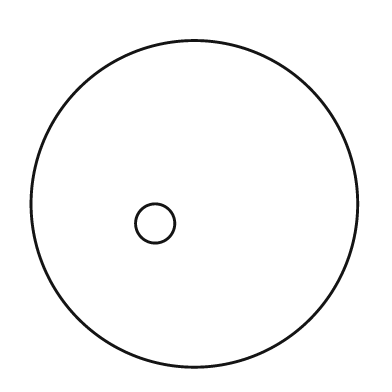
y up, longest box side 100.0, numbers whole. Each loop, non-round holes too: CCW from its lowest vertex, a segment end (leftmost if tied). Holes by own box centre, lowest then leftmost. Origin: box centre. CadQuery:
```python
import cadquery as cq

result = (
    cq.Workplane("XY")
    .moveTo(0.0, 0.0)
    .circle(50.0)
    .moveTo(-12.0, -6.0)
    .circle(6.0)
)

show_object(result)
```